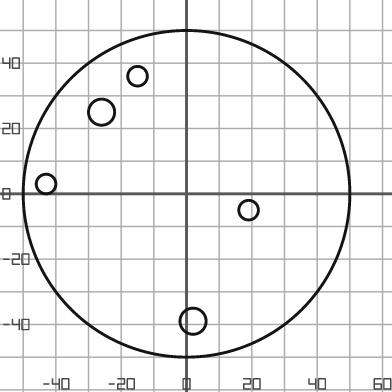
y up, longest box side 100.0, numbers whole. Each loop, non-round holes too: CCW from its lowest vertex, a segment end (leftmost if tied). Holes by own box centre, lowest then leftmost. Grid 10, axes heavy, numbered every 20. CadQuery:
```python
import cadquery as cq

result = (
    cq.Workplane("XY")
    .moveTo(0.0, 0.0)
    .circle(50.0)
    .moveTo(2.0, -39.0)
    .circle(4.0)
    .moveTo(19.0, -5.0)
    .circle(3.0)
    .moveTo(-43.0, 3.0)
    .circle(3.0)
    .moveTo(-26.0, 25.0)
    .circle(4.0)
    .moveTo(-15.0, 36.0)
    .circle(3.0)
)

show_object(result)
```